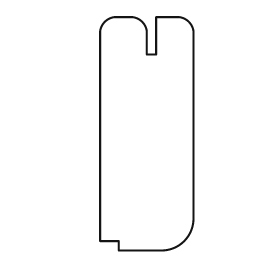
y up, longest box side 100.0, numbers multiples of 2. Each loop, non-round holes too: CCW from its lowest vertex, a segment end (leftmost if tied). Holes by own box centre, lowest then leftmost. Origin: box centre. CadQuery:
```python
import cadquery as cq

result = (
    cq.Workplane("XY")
    .moveTo(-12.0, -50.0)
    .lineTo(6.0, -50.0)
    .threePointArc((16.0, -46.0), (20.0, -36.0))
    .lineTo(20.0, 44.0)
    .threePointArc((18.0, 48.0), (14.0, 50.0))
    .lineTo(4.0, 50.0)
    .lineTo(4.0, 34.0)
    .lineTo(0.0, 34.0)
    .lineTo(0.0, 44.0)
    .threePointArc((-2.0, 48.0), (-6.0, 50.0))
    .lineTo(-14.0, 50.0)
    .threePointArc((-18.0, 48.0), (-20.0, 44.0))
    .lineTo(-20.0, -46.0)
    .lineTo(-12.0, -46.0)
    .close()
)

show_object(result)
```